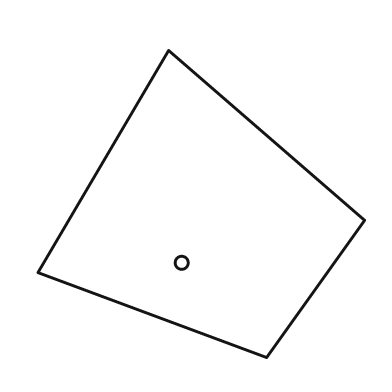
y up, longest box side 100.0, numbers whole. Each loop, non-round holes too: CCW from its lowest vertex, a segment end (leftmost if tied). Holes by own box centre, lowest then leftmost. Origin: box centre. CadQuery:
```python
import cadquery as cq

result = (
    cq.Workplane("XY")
    .moveTo(20.0, -47.0)
    .lineTo(50.0, -5.0)
    .lineTo(-10.0, 47.0)
    .lineTo(-50.0, -21.0)
    .close()
    .moveTo(-6.0, -18.0)
    .circle(2.0)
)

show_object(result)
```